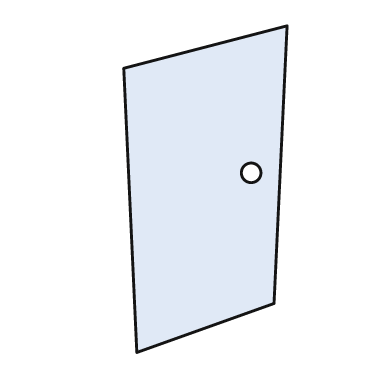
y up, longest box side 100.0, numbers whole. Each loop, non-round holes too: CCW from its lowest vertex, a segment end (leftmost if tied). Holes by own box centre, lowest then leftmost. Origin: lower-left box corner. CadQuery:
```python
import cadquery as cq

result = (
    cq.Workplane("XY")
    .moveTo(4.0, 0.0)
    .lineTo(46.0, 15.0)
    .lineTo(50.0, 100.0)
    .lineTo(0.0, 87.0)
    .close()
    .moveTo(39.0, 55.0)
    .circle(3.0)
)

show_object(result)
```